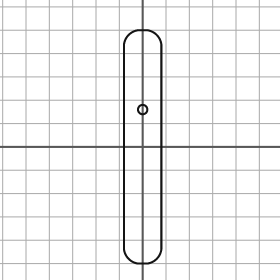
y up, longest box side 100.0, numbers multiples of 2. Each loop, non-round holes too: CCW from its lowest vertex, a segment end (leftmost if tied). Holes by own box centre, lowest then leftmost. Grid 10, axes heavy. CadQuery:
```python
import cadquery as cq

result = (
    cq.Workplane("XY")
    .moveTo(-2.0, -50.0)
    .lineTo(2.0, -50.0)
    .threePointArc((6.0, -48.0), (8.0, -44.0))
    .lineTo(8.0, 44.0)
    .threePointArc((6.0, 48.0), (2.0, 50.0))
    .lineTo(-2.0, 50.0)
    .threePointArc((-6.0, 48.0), (-8.0, 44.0))
    .lineTo(-8.0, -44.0)
    .threePointArc((-6.0, -48.0), (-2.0, -50.0))
    .close()
    .moveTo(0.0, 16.0)
    .circle(2.0)
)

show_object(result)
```